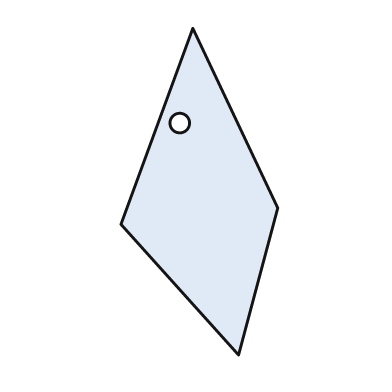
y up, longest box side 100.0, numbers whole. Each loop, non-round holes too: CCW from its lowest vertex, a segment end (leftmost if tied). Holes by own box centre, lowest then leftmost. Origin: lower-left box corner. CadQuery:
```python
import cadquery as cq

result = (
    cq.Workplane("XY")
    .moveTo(36.0, 0.0)
    .lineTo(48.0, 45.0)
    .lineTo(22.0, 100.0)
    .lineTo(0.0, 40.0)
    .close()
    .moveTo(18.0, 71.0)
    .circle(3.0)
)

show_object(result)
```